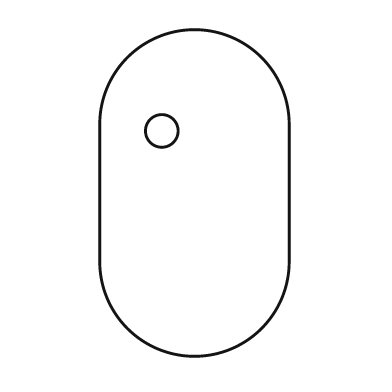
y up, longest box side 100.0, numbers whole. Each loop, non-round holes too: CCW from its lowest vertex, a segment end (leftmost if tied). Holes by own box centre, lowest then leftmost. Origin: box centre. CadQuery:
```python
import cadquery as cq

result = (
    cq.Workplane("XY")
    .moveTo(-29.0, -21.0)
    .threePointArc((0.0, -50.0), (29.0, -21.0))
    .lineTo(29.0, 21.0)
    .threePointArc((0.0, 50.0), (-29.0, 21.0))
    .close()
    .moveTo(-10.0, 19.0)
    .circle(5.0)
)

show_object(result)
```